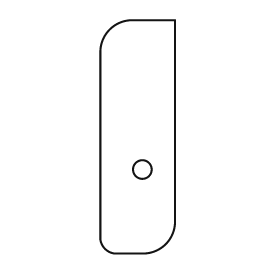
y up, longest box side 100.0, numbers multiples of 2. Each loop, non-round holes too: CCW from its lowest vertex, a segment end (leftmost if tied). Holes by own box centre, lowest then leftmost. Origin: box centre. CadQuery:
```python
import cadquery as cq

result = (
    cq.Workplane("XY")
    .moveTo(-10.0, -50.0)
    .lineTo(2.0, -50.0)
    .threePointArc((12.0, -46.0), (16.0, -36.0))
    .lineTo(16.0, 50.0)
    .lineTo(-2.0, 50.0)
    .threePointArc((-12.0, 46.0), (-16.0, 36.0))
    .lineTo(-16.0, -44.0)
    .threePointArc((-14.0, -48.0), (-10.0, -50.0))
    .close()
    .moveTo(2.0, -14.0)
    .circle(4.0)
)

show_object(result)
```